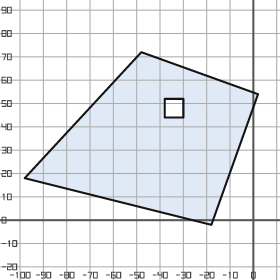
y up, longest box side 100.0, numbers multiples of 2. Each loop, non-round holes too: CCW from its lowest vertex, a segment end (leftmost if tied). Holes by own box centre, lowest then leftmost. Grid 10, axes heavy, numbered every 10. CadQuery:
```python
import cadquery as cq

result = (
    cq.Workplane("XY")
    .moveTo(-18.0, -2.0)
    .lineTo(2.0, 54.0)
    .lineTo(-48.0, 72.0)
    .lineTo(-98.0, 18.0)
    .close()
    .moveTo(-38.0, 44.0)
    .lineTo(-30.0, 44.0)
    .lineTo(-30.0, 52.0)
    .lineTo(-38.0, 52.0)
    .close()
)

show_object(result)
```